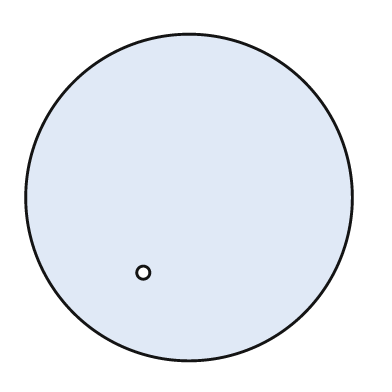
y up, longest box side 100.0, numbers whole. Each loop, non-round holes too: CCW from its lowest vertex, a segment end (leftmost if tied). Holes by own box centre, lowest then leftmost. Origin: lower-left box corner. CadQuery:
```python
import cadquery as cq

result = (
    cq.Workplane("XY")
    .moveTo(50.0, 50.0)
    .circle(50.0)
    .moveTo(36.0, 27.0)
    .circle(2.0)
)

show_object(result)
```